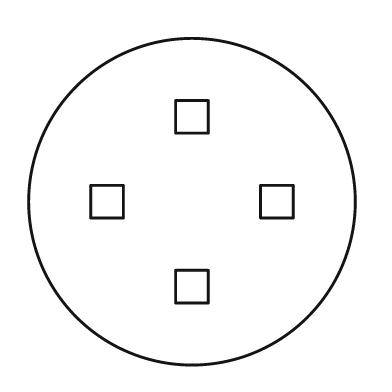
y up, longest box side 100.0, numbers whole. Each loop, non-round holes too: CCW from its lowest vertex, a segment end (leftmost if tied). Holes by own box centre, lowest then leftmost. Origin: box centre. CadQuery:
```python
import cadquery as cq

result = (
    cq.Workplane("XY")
    .moveTo(0.0, 0.0)
    .circle(50.0)
    .moveTo(-5.0, -31.0)
    .lineTo(5.0, -31.0)
    .lineTo(5.0, -21.0)
    .lineTo(-5.0, -21.0)
    .close()
    .moveTo(-31.0, -5.0)
    .lineTo(-21.0, -5.0)
    .lineTo(-21.0, 5.0)
    .lineTo(-31.0, 5.0)
    .close()
    .moveTo(21.0, -5.0)
    .lineTo(31.0, -5.0)
    .lineTo(31.0, 5.0)
    .lineTo(21.0, 5.0)
    .close()
    .moveTo(-5.0, 21.0)
    .lineTo(5.0, 21.0)
    .lineTo(5.0, 31.0)
    .lineTo(-5.0, 31.0)
    .close()
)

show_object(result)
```